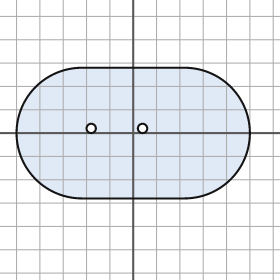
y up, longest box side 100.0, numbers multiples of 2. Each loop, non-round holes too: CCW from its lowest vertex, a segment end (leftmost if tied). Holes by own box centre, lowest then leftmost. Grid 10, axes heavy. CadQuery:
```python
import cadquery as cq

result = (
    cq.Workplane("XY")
    .moveTo(-22.0, -28.0)
    .lineTo(22.0, -28.0)
    .threePointArc((50.0, 0.0), (22.0, 28.0))
    .lineTo(-22.0, 28.0)
    .threePointArc((-50.0, 0.0), (-22.0, -28.0))
    .close()
    .moveTo(-18.0, 2.0)
    .circle(2.0)
    .moveTo(4.0, 2.0)
    .circle(2.0)
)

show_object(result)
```